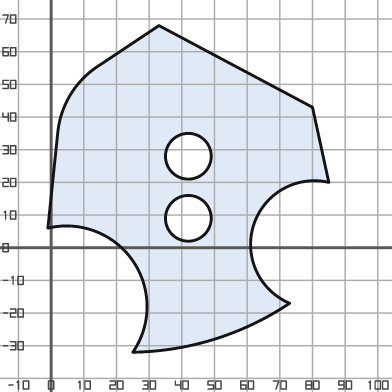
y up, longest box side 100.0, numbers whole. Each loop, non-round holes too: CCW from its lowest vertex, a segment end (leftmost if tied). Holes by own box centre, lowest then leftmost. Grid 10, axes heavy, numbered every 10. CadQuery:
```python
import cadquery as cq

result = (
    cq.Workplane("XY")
    .moveTo(25.0, -32.0)
    .threePointArc((50.0, -28.0), (73.0, -17.0))
    .threePointArc((62.0, 7.0), (85.0, 20.0))
    .lineTo(80.0, 43.0)
    .lineTo(33.0, 68.0)
    .lineTo(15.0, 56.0)
    .threePointArc((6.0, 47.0), (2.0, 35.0))
    .lineTo(-1.0, 6.0)
    .threePointArc((25.0, -4.0), (25.0, -32.0))
    .close()
    .moveTo(42.0, 9.0)
    .circle(7.0)
    .moveTo(42.0, 28.0)
    .circle(7.0)
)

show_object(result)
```